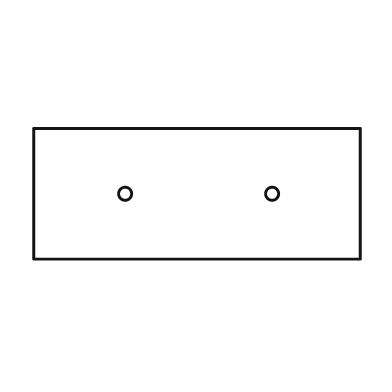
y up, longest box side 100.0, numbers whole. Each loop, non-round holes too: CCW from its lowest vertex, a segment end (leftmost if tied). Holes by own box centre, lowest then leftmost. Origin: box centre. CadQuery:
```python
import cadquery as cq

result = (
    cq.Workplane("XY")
    .moveTo(-50.0, -20.0)
    .lineTo(50.0, -20.0)
    .lineTo(50.0, 20.0)
    .lineTo(-50.0, 20.0)
    .close()
    .moveTo(-22.0, 0.0)
    .circle(2.0)
    .moveTo(23.0, 0.0)
    .circle(2.0)
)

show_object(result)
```